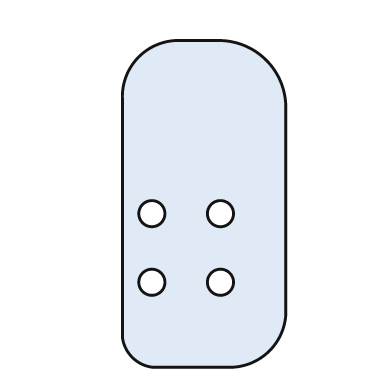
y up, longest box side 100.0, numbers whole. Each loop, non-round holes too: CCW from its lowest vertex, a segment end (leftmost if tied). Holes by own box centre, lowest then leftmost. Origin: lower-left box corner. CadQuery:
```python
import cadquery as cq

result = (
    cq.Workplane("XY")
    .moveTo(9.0, 0.0)
    .lineTo(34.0, 0.0)
    .threePointArc((45.0, 5.0), (50.0, 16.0))
    .lineTo(50.0, 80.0)
    .threePointArc((44.0, 94.0), (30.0, 100.0))
    .lineTo(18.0, 100.0)
    .threePointArc((5.0, 95.0), (0.0, 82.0))
    .lineTo(0.0, 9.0)
    .threePointArc((3.0, 3.0), (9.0, 0.0))
    .close()
    .moveTo(9.0, 26.0)
    .circle(4.0)
    .moveTo(30.0, 26.0)
    .circle(4.0)
    .moveTo(9.0, 47.0)
    .circle(4.0)
    .moveTo(30.0, 47.0)
    .circle(4.0)
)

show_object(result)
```